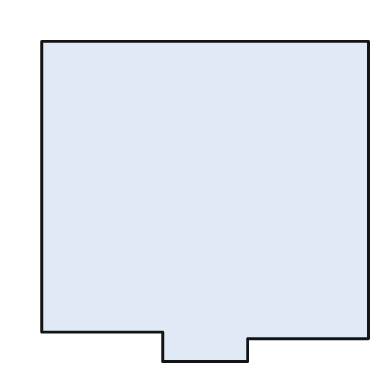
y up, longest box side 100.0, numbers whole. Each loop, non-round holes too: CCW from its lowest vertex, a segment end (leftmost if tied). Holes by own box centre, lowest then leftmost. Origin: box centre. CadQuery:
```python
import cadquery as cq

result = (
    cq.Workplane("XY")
    .moveTo(-13.0, -49.0)
    .lineTo(13.0, -49.0)
    .lineTo(13.0, -42.0)
    .lineTo(50.0, -42.0)
    .lineTo(50.0, 49.0)
    .lineTo(-50.0, 49.0)
    .lineTo(-50.0, -40.0)
    .lineTo(-13.0, -40.0)
    .close()
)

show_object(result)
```